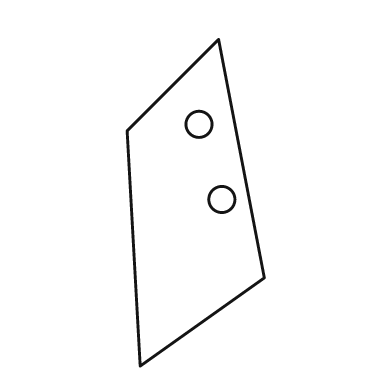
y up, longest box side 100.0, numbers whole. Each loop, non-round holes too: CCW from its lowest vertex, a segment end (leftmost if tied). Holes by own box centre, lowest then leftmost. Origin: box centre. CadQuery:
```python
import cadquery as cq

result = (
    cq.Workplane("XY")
    .moveTo(-17.0, -50.0)
    .lineTo(21.0, -23.0)
    .lineTo(7.0, 50.0)
    .lineTo(-21.0, 22.0)
    .close()
    .moveTo(8.0, 1.0)
    .circle(4.0)
    .moveTo(1.0, 24.0)
    .circle(4.0)
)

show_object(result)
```